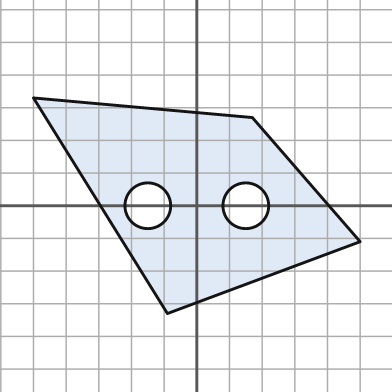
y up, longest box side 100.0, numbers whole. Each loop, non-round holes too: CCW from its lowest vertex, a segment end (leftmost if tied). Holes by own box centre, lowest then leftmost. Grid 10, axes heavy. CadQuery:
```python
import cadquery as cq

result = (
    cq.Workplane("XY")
    .moveTo(-9.0, -33.0)
    .lineTo(50.0, -11.0)
    .lineTo(17.0, 27.0)
    .lineTo(-50.0, 33.0)
    .close()
    .moveTo(-15.0, 0.0)
    .circle(7.0)
    .moveTo(15.0, 0.0)
    .circle(7.0)
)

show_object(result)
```